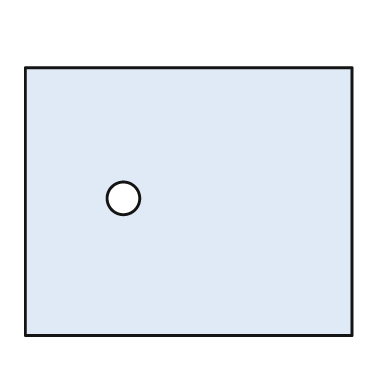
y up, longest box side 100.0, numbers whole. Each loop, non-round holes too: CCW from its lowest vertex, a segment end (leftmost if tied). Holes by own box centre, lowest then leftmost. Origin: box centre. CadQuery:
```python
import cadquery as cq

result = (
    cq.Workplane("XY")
    .moveTo(-50.0, -41.0)
    .lineTo(50.0, -41.0)
    .lineTo(50.0, 41.0)
    .lineTo(-50.0, 41.0)
    .close()
    .moveTo(-20.0, 1.0)
    .circle(5.0)
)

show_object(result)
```